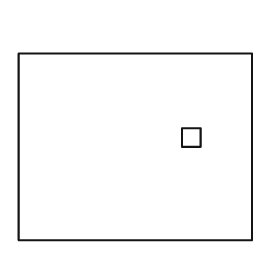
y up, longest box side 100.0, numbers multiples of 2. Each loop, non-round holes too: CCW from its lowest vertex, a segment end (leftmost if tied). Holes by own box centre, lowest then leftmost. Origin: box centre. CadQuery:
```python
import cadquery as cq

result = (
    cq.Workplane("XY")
    .moveTo(-50.0, -40.0)
    .lineTo(50.0, -40.0)
    .lineTo(50.0, 40.0)
    .lineTo(-50.0, 40.0)
    .close()
    .moveTo(20.0, 0.0)
    .lineTo(28.0, 0.0)
    .lineTo(28.0, 8.0)
    .lineTo(20.0, 8.0)
    .close()
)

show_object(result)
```